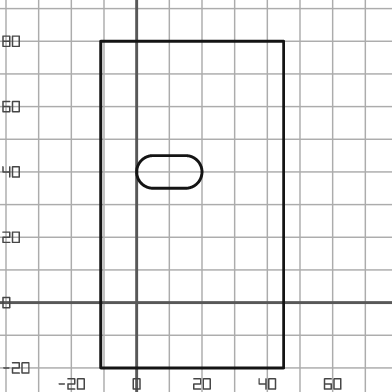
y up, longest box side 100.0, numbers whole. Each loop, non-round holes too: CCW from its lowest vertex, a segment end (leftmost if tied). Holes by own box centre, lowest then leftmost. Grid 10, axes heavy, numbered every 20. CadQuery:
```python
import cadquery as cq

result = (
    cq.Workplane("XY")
    .moveTo(-11.0, -20.0)
    .lineTo(45.0, -20.0)
    .lineTo(45.0, 80.0)
    .lineTo(-11.0, 80.0)
    .close()
    .moveTo(5.0, 35.0)
    .lineTo(15.0, 35.0)
    .threePointArc((20.0, 40.0), (15.0, 45.0))
    .lineTo(5.0, 45.0)
    .threePointArc((0.0, 40.0), (5.0, 35.0))
    .close()
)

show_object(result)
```